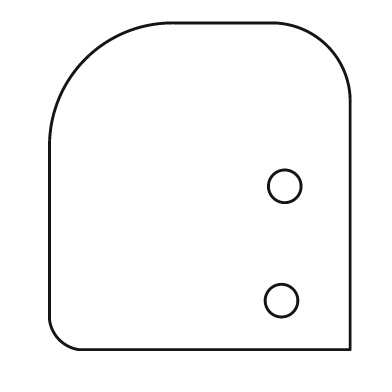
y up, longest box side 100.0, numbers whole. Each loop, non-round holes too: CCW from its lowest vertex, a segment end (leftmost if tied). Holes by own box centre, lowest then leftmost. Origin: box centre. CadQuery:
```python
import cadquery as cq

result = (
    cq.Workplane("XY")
    .moveTo(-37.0, -50.0)
    .lineTo(46.0, -50.0)
    .lineTo(46.0, 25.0)
    .threePointArc((39.0, 43.0), (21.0, 50.0))
    .lineTo(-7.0, 50.0)
    .threePointArc((-35.0, 39.0), (-46.0, 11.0))
    .lineTo(-46.0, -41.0)
    .threePointArc((-43.0, -47.0), (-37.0, -50.0))
    .close()
    .moveTo(25.0, -35.0)
    .circle(5.0)
    .moveTo(26.0, 0.0)
    .circle(5.0)
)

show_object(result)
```